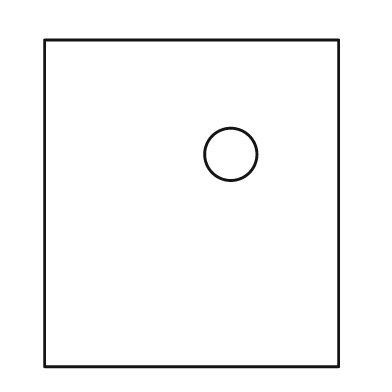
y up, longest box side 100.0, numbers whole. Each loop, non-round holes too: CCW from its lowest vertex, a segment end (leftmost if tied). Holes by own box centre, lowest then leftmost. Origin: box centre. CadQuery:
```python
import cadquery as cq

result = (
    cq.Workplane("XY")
    .moveTo(-45.0, -50.0)
    .lineTo(45.0, -50.0)
    .lineTo(45.0, 50.0)
    .lineTo(-45.0, 50.0)
    .close()
    .moveTo(12.0, 15.0)
    .circle(8.0)
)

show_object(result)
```